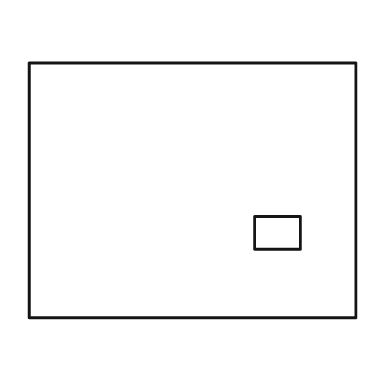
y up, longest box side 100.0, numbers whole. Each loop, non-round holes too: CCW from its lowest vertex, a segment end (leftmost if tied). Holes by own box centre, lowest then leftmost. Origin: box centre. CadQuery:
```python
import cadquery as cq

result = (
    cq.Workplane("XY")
    .moveTo(-50.0, -39.0)
    .lineTo(50.0, -39.0)
    .lineTo(50.0, 39.0)
    .lineTo(-50.0, 39.0)
    .close()
    .moveTo(19.0, -18.0)
    .lineTo(33.0, -18.0)
    .lineTo(33.0, -8.0)
    .lineTo(19.0, -8.0)
    .close()
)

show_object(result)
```